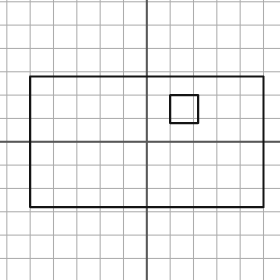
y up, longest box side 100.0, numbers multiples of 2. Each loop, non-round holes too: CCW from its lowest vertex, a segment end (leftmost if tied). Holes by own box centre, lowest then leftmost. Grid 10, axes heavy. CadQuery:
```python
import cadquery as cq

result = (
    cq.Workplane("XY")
    .moveTo(-50.0, -28.0)
    .lineTo(50.0, -28.0)
    .lineTo(50.0, 28.0)
    .lineTo(-50.0, 28.0)
    .close()
    .moveTo(10.0, 8.0)
    .lineTo(22.0, 8.0)
    .lineTo(22.0, 20.0)
    .lineTo(10.0, 20.0)
    .close()
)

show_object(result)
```